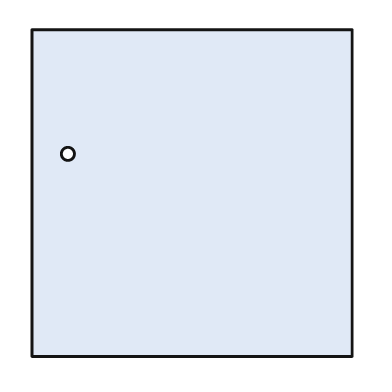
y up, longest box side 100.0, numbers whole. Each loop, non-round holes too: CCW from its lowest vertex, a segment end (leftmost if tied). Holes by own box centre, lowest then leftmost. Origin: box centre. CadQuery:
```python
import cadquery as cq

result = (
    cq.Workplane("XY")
    .moveTo(-49.0, -50.0)
    .lineTo(49.0, -50.0)
    .lineTo(49.0, 50.0)
    .lineTo(-49.0, 50.0)
    .close()
    .moveTo(-38.0, 12.0)
    .circle(2.0)
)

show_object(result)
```